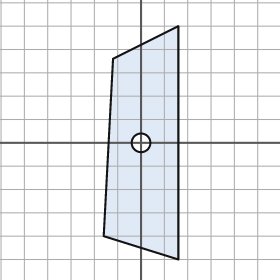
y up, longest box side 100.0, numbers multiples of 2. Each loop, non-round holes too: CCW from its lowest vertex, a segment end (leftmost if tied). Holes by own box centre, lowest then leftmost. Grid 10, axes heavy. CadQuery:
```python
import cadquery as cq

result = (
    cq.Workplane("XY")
    .moveTo(16.0, -50.0)
    .lineTo(16.0, 50.0)
    .lineTo(-12.0, 36.0)
    .lineTo(-16.0, -40.0)
    .close()
    .moveTo(0.0, 0.0)
    .circle(4.0)
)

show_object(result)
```